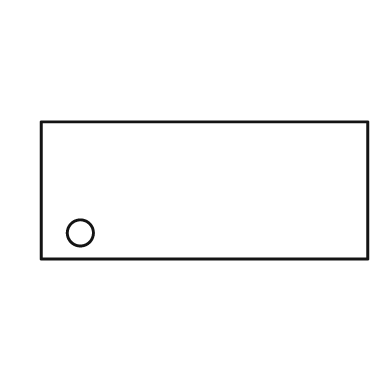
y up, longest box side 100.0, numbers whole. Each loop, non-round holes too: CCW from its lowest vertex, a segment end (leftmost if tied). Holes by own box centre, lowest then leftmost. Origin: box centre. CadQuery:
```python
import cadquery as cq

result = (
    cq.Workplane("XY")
    .moveTo(-50.0, -21.0)
    .lineTo(50.0, -21.0)
    .lineTo(50.0, 21.0)
    .lineTo(-50.0, 21.0)
    .close()
    .moveTo(-38.0, -13.0)
    .circle(4.0)
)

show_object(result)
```